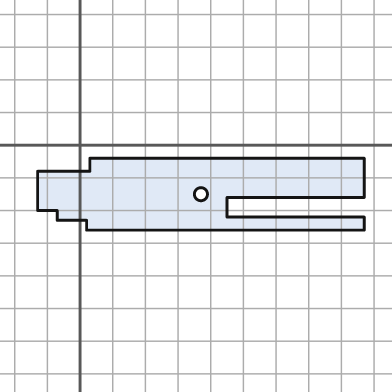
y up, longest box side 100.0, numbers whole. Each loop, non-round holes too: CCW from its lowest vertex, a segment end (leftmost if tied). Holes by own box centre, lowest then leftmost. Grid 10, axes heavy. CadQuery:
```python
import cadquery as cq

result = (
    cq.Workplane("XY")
    .moveTo(2.0, -26.0)
    .lineTo(87.0, -26.0)
    .lineTo(87.0, -22.0)
    .lineTo(45.0, -22.0)
    .lineTo(45.0, -16.0)
    .lineTo(87.0, -16.0)
    .lineTo(87.0, -4.0)
    .lineTo(3.0, -4.0)
    .lineTo(3.0, -8.0)
    .lineTo(-13.0, -8.0)
    .lineTo(-13.0, -20.0)
    .lineTo(-7.0, -20.0)
    .lineTo(-7.0, -23.0)
    .lineTo(2.0, -23.0)
    .close()
    .moveTo(37.0, -15.0)
    .circle(2.0)
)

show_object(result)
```